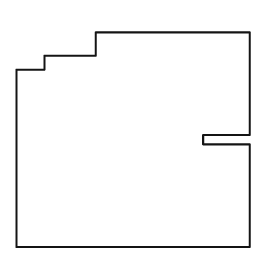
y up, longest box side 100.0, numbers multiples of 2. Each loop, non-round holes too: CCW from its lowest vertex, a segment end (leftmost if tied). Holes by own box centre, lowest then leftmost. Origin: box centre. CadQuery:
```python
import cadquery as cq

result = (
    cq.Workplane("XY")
    .moveTo(-50.0, -46.0)
    .lineTo(50.0, -46.0)
    .lineTo(50.0, -2.0)
    .lineTo(30.0, -2.0)
    .lineTo(30.0, 2.0)
    .lineTo(50.0, 2.0)
    .lineTo(50.0, 46.0)
    .lineTo(-16.0, 46.0)
    .lineTo(-16.0, 36.0)
    .lineTo(-38.0, 36.0)
    .lineTo(-38.0, 30.0)
    .lineTo(-50.0, 30.0)
    .close()
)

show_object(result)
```